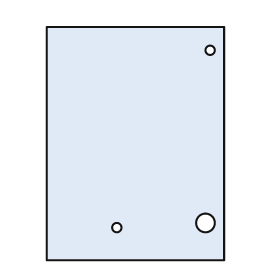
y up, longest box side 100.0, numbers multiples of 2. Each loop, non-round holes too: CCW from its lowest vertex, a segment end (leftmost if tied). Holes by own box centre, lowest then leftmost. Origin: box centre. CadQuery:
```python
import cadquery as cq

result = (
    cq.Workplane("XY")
    .moveTo(-38.0, -50.0)
    .lineTo(38.0, -50.0)
    .lineTo(38.0, 50.0)
    .lineTo(-38.0, 50.0)
    .close()
    .moveTo(-8.0, -36.0)
    .circle(2.0)
    .moveTo(30.0, -34.0)
    .circle(4.0)
    .moveTo(32.0, 40.0)
    .circle(2.0)
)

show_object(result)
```